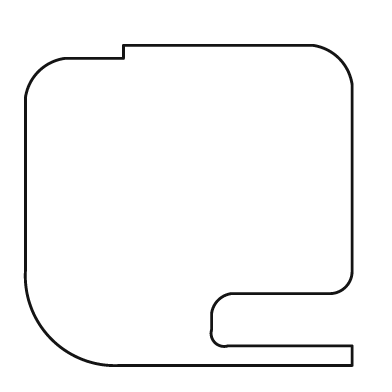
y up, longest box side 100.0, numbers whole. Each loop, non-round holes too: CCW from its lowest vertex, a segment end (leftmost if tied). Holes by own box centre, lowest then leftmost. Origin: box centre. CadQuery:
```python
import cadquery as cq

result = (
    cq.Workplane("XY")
    .moveTo(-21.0, -49.0)
    .lineTo(50.0, -49.0)
    .lineTo(50.0, -43.0)
    .lineTo(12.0, -43.0)
    .threePointArc((8.0, -42.0), (7.0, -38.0))
    .lineTo(7.0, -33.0)
    .threePointArc((9.0, -29.0), (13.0, -27.0))
    .lineTo(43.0, -27.0)
    .threePointArc((48.0, -25.0), (50.0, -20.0))
    .lineTo(50.0, 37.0)
    .threePointArc((46.0, 45.0), (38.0, 49.0))
    .lineTo(-20.0, 49.0)
    .lineTo(-20.0, 45.0)
    .lineTo(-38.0, 45.0)
    .threePointArc((-46.0, 41.0), (-50.0, 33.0))
    .lineTo(-50.0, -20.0)
    .threePointArc((-42.0, -41.0), (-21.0, -49.0))
    .close()
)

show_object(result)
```